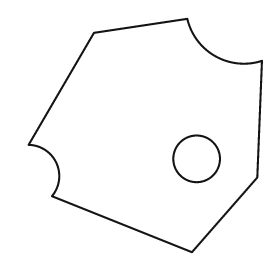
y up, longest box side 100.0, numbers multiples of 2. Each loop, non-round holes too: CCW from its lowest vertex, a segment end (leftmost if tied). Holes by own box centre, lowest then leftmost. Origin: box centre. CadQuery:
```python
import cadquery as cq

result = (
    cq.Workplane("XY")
    .moveTo(20.0, -50.0)
    .lineTo(48.0, -18.0)
    .lineTo(50.0, 32.0)
    .threePointArc((30.0, 34.0), (18.0, 50.0))
    .lineTo(-22.0, 44.0)
    .lineTo(-50.0, -4.0)
    .threePointArc((-38.0, -12.0), (-40.0, -26.0))
    .close()
    .moveTo(22.0, -10.0)
    .circle(10.0)
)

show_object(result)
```